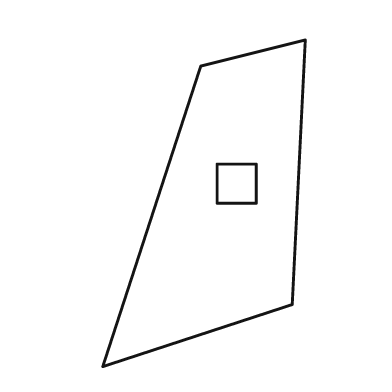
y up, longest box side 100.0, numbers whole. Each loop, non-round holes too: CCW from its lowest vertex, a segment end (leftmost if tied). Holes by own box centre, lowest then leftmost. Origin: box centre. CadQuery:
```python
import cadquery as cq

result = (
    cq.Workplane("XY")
    .moveTo(-31.0, -50.0)
    .lineTo(27.0, -31.0)
    .lineTo(31.0, 50.0)
    .lineTo(-1.0, 42.0)
    .close()
    .moveTo(4.0, 0.0)
    .lineTo(16.0, 0.0)
    .lineTo(16.0, 12.0)
    .lineTo(4.0, 12.0)
    .close()
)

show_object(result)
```